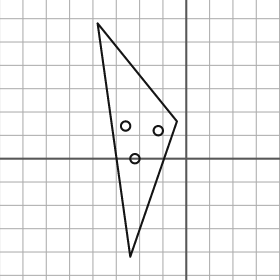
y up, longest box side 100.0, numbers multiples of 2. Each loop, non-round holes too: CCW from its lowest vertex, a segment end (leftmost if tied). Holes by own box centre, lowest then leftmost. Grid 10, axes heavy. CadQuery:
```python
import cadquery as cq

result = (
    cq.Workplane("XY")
    .moveTo(-24.0, -42.0)
    .lineTo(-4.0, 16.0)
    .lineTo(-38.0, 58.0)
    .close()
    .moveTo(-22.0, 0.0)
    .circle(2.0)
    .moveTo(-12.0, 12.0)
    .circle(2.0)
    .moveTo(-26.0, 14.0)
    .circle(2.0)
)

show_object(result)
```